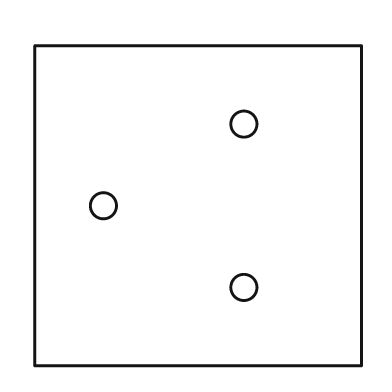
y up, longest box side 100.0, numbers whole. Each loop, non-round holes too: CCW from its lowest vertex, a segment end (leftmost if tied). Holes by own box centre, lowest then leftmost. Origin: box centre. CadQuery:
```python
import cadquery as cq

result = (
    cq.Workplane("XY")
    .moveTo(-50.0, -49.0)
    .lineTo(50.0, -49.0)
    .lineTo(50.0, 49.0)
    .lineTo(-50.0, 49.0)
    .close()
    .moveTo(14.0, -25.0)
    .circle(4.0)
    .moveTo(-29.0, 0.0)
    .circle(4.0)
    .moveTo(14.0, 25.0)
    .circle(4.0)
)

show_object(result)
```